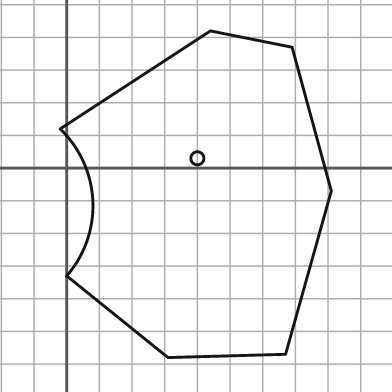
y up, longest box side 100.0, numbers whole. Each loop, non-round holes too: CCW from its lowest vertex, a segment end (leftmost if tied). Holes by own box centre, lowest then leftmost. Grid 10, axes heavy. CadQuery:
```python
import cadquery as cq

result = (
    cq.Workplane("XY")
    .moveTo(31.0, -58.0)
    .lineTo(67.0, -57.0)
    .lineTo(81.0, -7.0)
    .lineTo(69.0, 37.0)
    .lineTo(44.0, 42.0)
    .lineTo(-2.0, 12.0)
    .threePointArc((8.0, -10.0), (0.0, -33.0))
    .close()
    .moveTo(40.0, 3.0)
    .circle(2.0)
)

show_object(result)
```